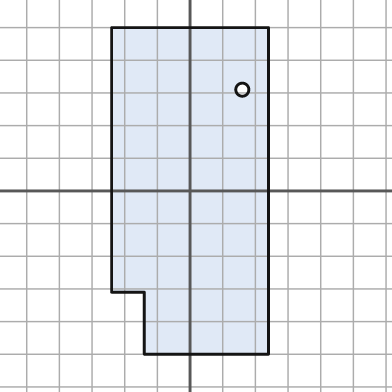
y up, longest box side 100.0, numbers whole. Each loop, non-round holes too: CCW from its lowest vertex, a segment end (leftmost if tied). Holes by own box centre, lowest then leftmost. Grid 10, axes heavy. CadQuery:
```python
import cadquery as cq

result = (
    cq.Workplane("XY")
    .moveTo(-14.0, -50.0)
    .lineTo(24.0, -50.0)
    .lineTo(24.0, 50.0)
    .lineTo(-24.0, 50.0)
    .lineTo(-24.0, -31.0)
    .lineTo(-14.0, -31.0)
    .close()
    .moveTo(16.0, 31.0)
    .circle(2.0)
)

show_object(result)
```